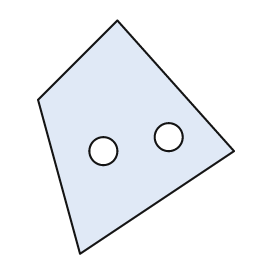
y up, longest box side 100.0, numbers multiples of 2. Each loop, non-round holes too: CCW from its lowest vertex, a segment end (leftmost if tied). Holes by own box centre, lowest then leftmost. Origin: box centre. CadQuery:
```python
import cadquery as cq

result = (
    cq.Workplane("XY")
    .moveTo(-24.0, -50.0)
    .lineTo(42.0, -6.0)
    .lineTo(-8.0, 50.0)
    .lineTo(-42.0, 16.0)
    .close()
    .moveTo(-14.0, -6.0)
    .circle(6.0)
    .moveTo(14.0, 0.0)
    .circle(6.0)
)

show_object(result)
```